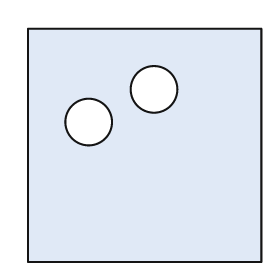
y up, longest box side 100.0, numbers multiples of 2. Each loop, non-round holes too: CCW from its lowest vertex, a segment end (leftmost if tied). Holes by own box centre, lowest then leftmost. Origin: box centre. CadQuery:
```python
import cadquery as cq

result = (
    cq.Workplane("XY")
    .moveTo(-50.0, -50.0)
    .lineTo(50.0, -50.0)
    .lineTo(50.0, 50.0)
    .lineTo(-50.0, 50.0)
    .close()
    .moveTo(-24.0, 10.0)
    .circle(10.0)
    .moveTo(4.0, 24.0)
    .circle(10.0)
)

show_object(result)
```